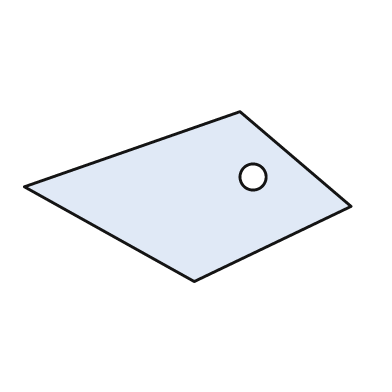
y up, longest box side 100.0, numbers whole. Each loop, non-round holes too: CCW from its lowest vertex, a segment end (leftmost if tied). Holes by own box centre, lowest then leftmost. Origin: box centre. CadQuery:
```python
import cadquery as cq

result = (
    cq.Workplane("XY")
    .moveTo(2.0, -26.0)
    .lineTo(50.0, -3.0)
    .lineTo(16.0, 26.0)
    .lineTo(-50.0, 3.0)
    .close()
    .moveTo(20.0, 6.0)
    .circle(4.0)
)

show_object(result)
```